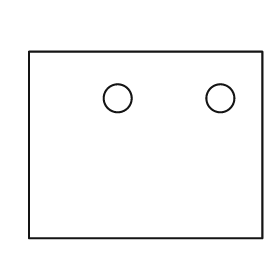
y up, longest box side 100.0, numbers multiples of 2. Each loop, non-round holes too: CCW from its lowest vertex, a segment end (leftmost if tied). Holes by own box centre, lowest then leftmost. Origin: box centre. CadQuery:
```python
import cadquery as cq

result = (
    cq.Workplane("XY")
    .moveTo(-50.0, -40.0)
    .lineTo(50.0, -40.0)
    .lineTo(50.0, 40.0)
    .lineTo(-50.0, 40.0)
    .close()
    .moveTo(-12.0, 20.0)
    .circle(6.0)
    .moveTo(32.0, 20.0)
    .circle(6.0)
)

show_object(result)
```